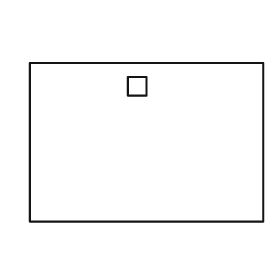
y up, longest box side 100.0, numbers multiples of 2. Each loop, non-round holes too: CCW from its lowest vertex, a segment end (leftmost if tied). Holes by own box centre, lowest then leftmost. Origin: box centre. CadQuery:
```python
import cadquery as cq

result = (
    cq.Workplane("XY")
    .moveTo(-50.0, -34.0)
    .lineTo(50.0, -34.0)
    .lineTo(50.0, 34.0)
    .lineTo(-50.0, 34.0)
    .close()
    .moveTo(-8.0, 20.0)
    .lineTo(0.0, 20.0)
    .lineTo(0.0, 28.0)
    .lineTo(-8.0, 28.0)
    .close()
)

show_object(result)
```